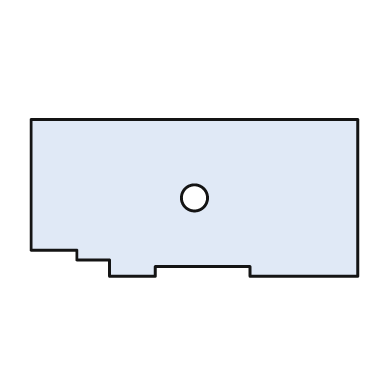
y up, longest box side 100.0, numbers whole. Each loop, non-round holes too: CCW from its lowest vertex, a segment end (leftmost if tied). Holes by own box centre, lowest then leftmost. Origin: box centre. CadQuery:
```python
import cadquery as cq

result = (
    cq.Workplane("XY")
    .moveTo(-26.0, -24.0)
    .lineTo(-12.0, -24.0)
    .lineTo(-12.0, -21.0)
    .lineTo(17.0, -21.0)
    .lineTo(17.0, -24.0)
    .lineTo(50.0, -24.0)
    .lineTo(50.0, 24.0)
    .lineTo(-50.0, 24.0)
    .lineTo(-50.0, -16.0)
    .lineTo(-36.0, -16.0)
    .lineTo(-36.0, -19.0)
    .lineTo(-26.0, -19.0)
    .close()
    .moveTo(0.0, 0.0)
    .circle(4.0)
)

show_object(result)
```